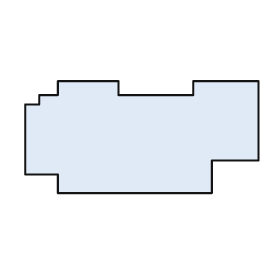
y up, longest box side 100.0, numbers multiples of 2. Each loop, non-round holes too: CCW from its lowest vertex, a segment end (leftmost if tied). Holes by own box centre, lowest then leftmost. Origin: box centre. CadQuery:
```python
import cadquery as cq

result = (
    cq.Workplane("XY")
    .moveTo(-36.0, -24.0)
    .lineTo(30.0, -24.0)
    .lineTo(30.0, -10.0)
    .lineTo(50.0, -10.0)
    .lineTo(50.0, 24.0)
    .lineTo(22.0, 24.0)
    .lineTo(22.0, 18.0)
    .lineTo(-10.0, 18.0)
    .lineTo(-10.0, 24.0)
    .lineTo(-36.0, 24.0)
    .lineTo(-36.0, 18.0)
    .lineTo(-44.0, 18.0)
    .lineTo(-44.0, 14.0)
    .lineTo(-50.0, 14.0)
    .lineTo(-50.0, -16.0)
    .lineTo(-36.0, -16.0)
    .close()
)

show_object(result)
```